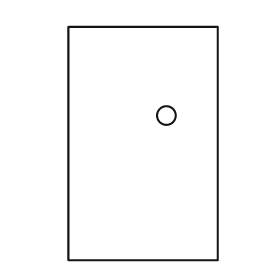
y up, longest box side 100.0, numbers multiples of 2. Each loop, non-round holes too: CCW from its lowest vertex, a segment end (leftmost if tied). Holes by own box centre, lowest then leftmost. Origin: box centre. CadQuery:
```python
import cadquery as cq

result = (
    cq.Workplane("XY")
    .moveTo(-32.0, -50.0)
    .lineTo(32.0, -50.0)
    .lineTo(32.0, 50.0)
    .lineTo(-32.0, 50.0)
    .close()
    .moveTo(10.0, 12.0)
    .circle(4.0)
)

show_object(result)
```